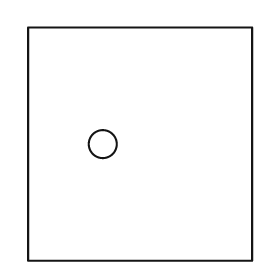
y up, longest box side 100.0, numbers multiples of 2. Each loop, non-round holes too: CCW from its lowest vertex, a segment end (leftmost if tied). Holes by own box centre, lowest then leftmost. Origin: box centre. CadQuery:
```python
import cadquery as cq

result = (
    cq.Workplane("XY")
    .moveTo(-48.0, -50.0)
    .lineTo(48.0, -50.0)
    .lineTo(48.0, 50.0)
    .lineTo(-48.0, 50.0)
    .close()
    .moveTo(-16.0, 0.0)
    .circle(6.0)
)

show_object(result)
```